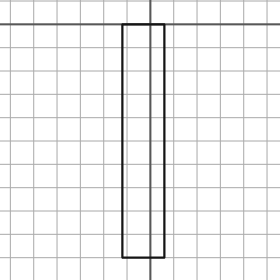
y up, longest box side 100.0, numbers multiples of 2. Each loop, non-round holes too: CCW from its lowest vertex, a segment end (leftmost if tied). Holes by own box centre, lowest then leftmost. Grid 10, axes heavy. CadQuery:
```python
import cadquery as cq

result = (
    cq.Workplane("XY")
    .moveTo(-12.0, -100.0)
    .lineTo(6.0, -100.0)
    .lineTo(6.0, 0.0)
    .lineTo(-12.0, 0.0)
    .close()
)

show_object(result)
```